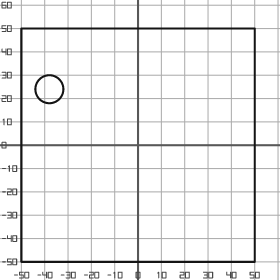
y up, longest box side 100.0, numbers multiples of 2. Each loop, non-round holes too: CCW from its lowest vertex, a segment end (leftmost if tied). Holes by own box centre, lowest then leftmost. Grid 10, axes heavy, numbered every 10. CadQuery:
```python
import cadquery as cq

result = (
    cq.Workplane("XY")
    .moveTo(-50.0, -50.0)
    .lineTo(50.0, -50.0)
    .lineTo(50.0, 50.0)
    .lineTo(-50.0, 50.0)
    .close()
    .moveTo(-38.0, 24.0)
    .circle(6.0)
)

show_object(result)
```